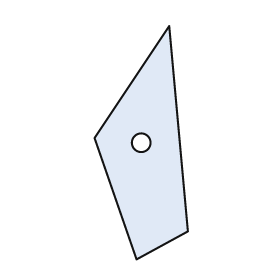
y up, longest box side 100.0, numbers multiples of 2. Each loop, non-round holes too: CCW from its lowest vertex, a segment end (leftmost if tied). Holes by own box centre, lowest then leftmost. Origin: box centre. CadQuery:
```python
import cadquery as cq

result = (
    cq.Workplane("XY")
    .moveTo(-2.0, -50.0)
    .lineTo(20.0, -38.0)
    .lineTo(12.0, 50.0)
    .lineTo(-20.0, 2.0)
    .close()
    .moveTo(0.0, 0.0)
    .circle(4.0)
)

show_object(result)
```